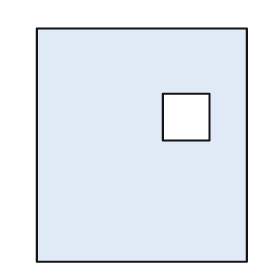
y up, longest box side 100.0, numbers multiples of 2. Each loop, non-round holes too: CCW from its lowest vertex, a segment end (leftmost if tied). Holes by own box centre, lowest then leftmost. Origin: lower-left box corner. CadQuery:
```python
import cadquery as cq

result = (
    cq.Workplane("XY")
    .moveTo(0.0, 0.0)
    .lineTo(90.0, 0.0)
    .lineTo(90.0, 100.0)
    .lineTo(0.0, 100.0)
    .close()
    .moveTo(54.0, 52.0)
    .lineTo(74.0, 52.0)
    .lineTo(74.0, 72.0)
    .lineTo(54.0, 72.0)
    .close()
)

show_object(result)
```